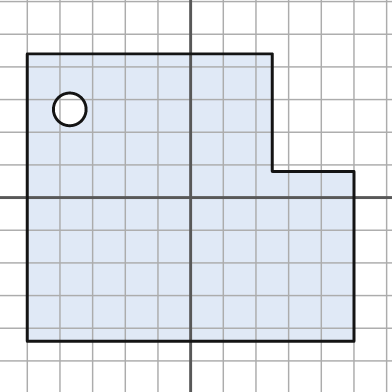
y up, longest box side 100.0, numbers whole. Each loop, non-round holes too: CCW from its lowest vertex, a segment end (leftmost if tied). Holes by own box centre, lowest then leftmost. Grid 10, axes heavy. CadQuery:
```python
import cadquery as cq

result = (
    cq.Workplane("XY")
    .moveTo(-50.0, -44.0)
    .lineTo(50.0, -44.0)
    .lineTo(50.0, 8.0)
    .lineTo(25.0, 8.0)
    .lineTo(25.0, 44.0)
    .lineTo(-50.0, 44.0)
    .close()
    .moveTo(-37.0, 27.0)
    .circle(5.0)
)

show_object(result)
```